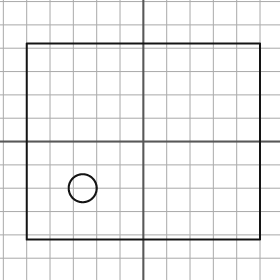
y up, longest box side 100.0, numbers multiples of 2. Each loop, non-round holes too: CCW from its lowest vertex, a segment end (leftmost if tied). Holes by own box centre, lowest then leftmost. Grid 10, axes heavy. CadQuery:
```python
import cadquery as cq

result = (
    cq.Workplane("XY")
    .moveTo(-50.0, -42.0)
    .lineTo(50.0, -42.0)
    .lineTo(50.0, 42.0)
    .lineTo(-50.0, 42.0)
    .close()
    .moveTo(-26.0, -20.0)
    .circle(6.0)
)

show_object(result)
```